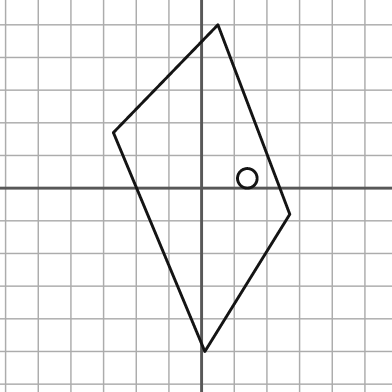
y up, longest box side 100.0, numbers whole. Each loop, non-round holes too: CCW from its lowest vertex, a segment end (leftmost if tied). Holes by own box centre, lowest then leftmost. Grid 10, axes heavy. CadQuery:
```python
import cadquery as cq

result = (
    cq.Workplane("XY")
    .moveTo(1.0, -50.0)
    .lineTo(27.0, -8.0)
    .lineTo(5.0, 50.0)
    .lineTo(-27.0, 17.0)
    .close()
    .moveTo(14.0, 3.0)
    .circle(3.0)
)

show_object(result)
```